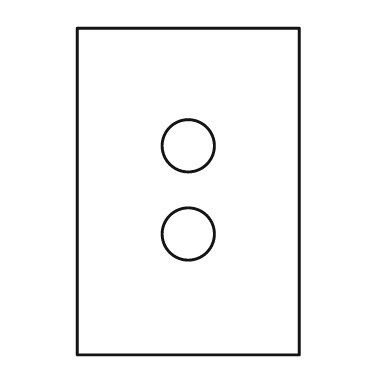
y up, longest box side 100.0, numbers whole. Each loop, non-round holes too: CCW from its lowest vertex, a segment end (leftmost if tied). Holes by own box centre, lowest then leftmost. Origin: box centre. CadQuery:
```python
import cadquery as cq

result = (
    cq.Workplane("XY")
    .moveTo(-34.0, -50.0)
    .lineTo(34.0, -50.0)
    .lineTo(34.0, 50.0)
    .lineTo(-34.0, 50.0)
    .close()
    .moveTo(0.0, -13.0)
    .circle(8.0)
    .moveTo(0.0, 14.0)
    .circle(8.0)
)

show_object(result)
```